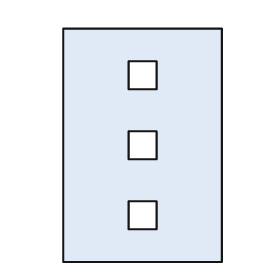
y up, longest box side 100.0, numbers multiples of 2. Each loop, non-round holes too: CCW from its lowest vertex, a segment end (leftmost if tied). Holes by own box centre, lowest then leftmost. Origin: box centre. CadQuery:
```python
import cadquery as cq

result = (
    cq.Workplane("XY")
    .moveTo(-34.0, -50.0)
    .lineTo(34.0, -50.0)
    .lineTo(34.0, 50.0)
    .lineTo(-34.0, 50.0)
    .close()
    .moveTo(-6.0, -36.0)
    .lineTo(6.0, -36.0)
    .lineTo(6.0, -24.0)
    .lineTo(-6.0, -24.0)
    .close()
    .moveTo(-6.0, -6.0)
    .lineTo(6.0, -6.0)
    .lineTo(6.0, 6.0)
    .lineTo(-6.0, 6.0)
    .close()
    .moveTo(-6.0, 24.0)
    .lineTo(6.0, 24.0)
    .lineTo(6.0, 36.0)
    .lineTo(-6.0, 36.0)
    .close()
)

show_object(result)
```